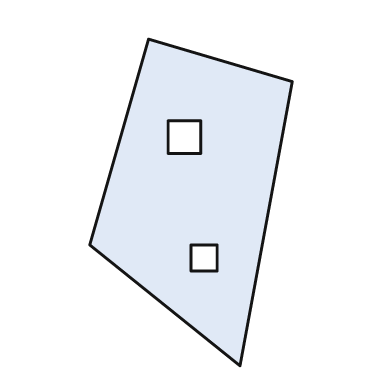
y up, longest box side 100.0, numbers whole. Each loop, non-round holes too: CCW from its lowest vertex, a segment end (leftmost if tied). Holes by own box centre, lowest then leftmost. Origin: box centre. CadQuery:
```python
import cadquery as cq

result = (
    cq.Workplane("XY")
    .moveTo(15.0, -50.0)
    .lineTo(31.0, 37.0)
    .lineTo(-13.0, 50.0)
    .lineTo(-31.0, -13.0)
    .close()
    .moveTo(0.0, -21.0)
    .lineTo(8.0, -21.0)
    .lineTo(8.0, -13.0)
    .lineTo(0.0, -13.0)
    .close()
    .moveTo(-7.0, 15.0)
    .lineTo(3.0, 15.0)
    .lineTo(3.0, 25.0)
    .lineTo(-7.0, 25.0)
    .close()
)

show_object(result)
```